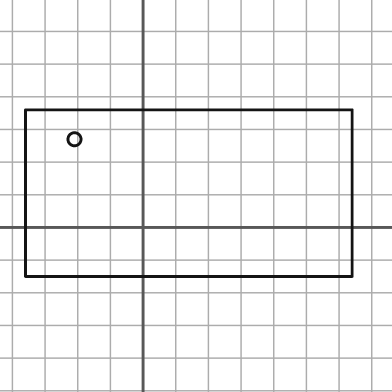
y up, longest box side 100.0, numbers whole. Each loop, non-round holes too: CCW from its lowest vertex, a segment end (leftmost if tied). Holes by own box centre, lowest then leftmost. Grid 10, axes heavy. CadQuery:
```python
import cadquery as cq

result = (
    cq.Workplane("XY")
    .moveTo(-36.0, -15.0)
    .lineTo(64.0, -15.0)
    .lineTo(64.0, 36.0)
    .lineTo(-36.0, 36.0)
    .close()
    .moveTo(-21.0, 27.0)
    .circle(2.0)
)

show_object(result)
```